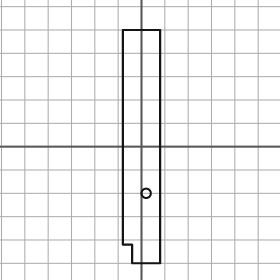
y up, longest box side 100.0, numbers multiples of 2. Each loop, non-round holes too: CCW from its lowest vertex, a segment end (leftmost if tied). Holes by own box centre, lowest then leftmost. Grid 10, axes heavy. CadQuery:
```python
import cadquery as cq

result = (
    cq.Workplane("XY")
    .moveTo(-4.0, -50.0)
    .lineTo(8.0, -50.0)
    .lineTo(8.0, 50.0)
    .lineTo(-8.0, 50.0)
    .lineTo(-8.0, -42.0)
    .lineTo(-4.0, -42.0)
    .close()
    .moveTo(2.0, -20.0)
    .circle(2.0)
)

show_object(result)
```